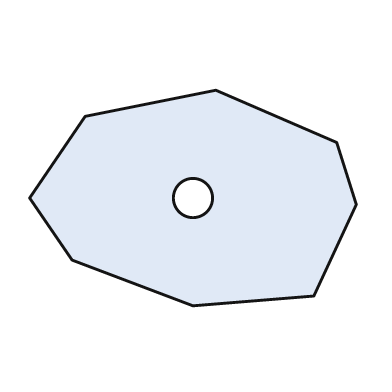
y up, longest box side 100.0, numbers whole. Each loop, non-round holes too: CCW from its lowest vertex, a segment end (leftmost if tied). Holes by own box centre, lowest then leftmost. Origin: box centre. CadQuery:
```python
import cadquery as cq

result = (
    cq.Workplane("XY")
    .moveTo(0.0, -33.0)
    .lineTo(37.0, -30.0)
    .lineTo(50.0, -2.0)
    .lineTo(44.0, 17.0)
    .lineTo(7.0, 33.0)
    .lineTo(-33.0, 25.0)
    .lineTo(-50.0, 0.0)
    .lineTo(-37.0, -19.0)
    .close()
    .moveTo(0.0, 0.0)
    .circle(6.0)
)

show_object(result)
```